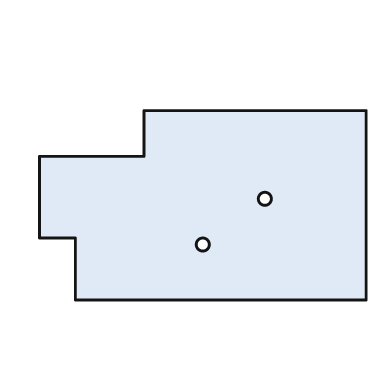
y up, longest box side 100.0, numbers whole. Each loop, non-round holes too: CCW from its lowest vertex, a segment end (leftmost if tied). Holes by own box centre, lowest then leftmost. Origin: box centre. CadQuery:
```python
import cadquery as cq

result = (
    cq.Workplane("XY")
    .moveTo(-39.0, -29.0)
    .lineTo(50.0, -29.0)
    .lineTo(50.0, 29.0)
    .lineTo(-18.0, 29.0)
    .lineTo(-18.0, 15.0)
    .lineTo(-50.0, 15.0)
    .lineTo(-50.0, -10.0)
    .lineTo(-39.0, -10.0)
    .close()
    .moveTo(0.0, -12.0)
    .circle(2.0)
    .moveTo(19.0, 2.0)
    .circle(2.0)
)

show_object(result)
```